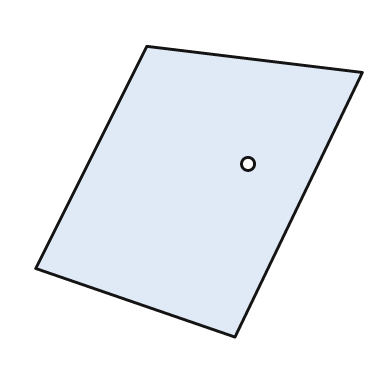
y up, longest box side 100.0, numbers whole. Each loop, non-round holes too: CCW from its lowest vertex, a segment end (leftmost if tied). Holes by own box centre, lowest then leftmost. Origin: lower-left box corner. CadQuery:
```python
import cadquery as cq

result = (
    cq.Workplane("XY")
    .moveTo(61.0, 0.0)
    .lineTo(100.0, 81.0)
    .lineTo(34.0, 89.0)
    .lineTo(0.0, 21.0)
    .close()
    .moveTo(65.0, 53.0)
    .circle(2.0)
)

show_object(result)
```